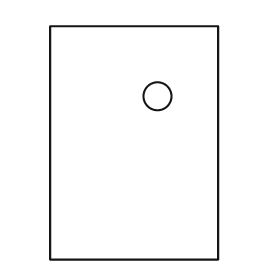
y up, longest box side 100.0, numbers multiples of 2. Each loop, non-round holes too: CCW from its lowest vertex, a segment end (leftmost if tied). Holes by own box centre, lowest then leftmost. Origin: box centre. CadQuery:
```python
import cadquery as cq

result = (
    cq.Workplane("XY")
    .moveTo(-36.0, -50.0)
    .lineTo(36.0, -50.0)
    .lineTo(36.0, 50.0)
    .lineTo(-36.0, 50.0)
    .close()
    .moveTo(10.0, 20.0)
    .circle(6.0)
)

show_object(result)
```